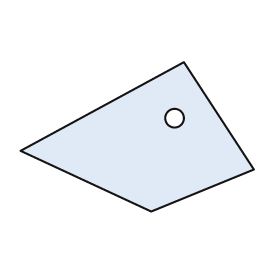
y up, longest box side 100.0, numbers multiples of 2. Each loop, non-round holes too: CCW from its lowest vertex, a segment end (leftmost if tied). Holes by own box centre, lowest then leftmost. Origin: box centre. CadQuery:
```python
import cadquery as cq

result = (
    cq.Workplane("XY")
    .moveTo(6.0, -32.0)
    .lineTo(50.0, -14.0)
    .lineTo(20.0, 32.0)
    .lineTo(-50.0, -6.0)
    .close()
    .moveTo(16.0, 8.0)
    .circle(4.0)
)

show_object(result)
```